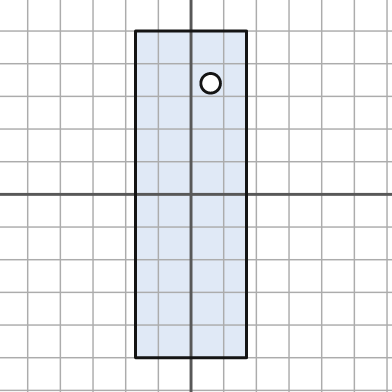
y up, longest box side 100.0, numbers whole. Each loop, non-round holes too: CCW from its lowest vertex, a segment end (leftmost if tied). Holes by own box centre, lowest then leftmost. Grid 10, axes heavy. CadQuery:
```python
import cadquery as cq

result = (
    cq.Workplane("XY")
    .moveTo(-17.0, -50.0)
    .lineTo(17.0, -50.0)
    .lineTo(17.0, 50.0)
    .lineTo(-17.0, 50.0)
    .close()
    .moveTo(6.0, 34.0)
    .circle(3.0)
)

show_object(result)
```